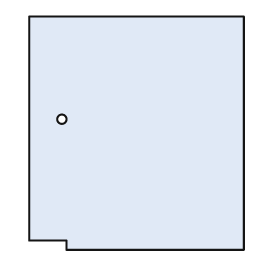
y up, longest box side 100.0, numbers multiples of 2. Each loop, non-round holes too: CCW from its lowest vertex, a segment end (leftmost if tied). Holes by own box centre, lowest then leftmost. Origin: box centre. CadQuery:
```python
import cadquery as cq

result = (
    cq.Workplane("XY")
    .moveTo(-30.0, -50.0)
    .lineTo(46.0, -50.0)
    .lineTo(46.0, 50.0)
    .lineTo(-46.0, 50.0)
    .lineTo(-46.0, -46.0)
    .lineTo(-30.0, -46.0)
    .close()
    .moveTo(-32.0, 6.0)
    .circle(2.0)
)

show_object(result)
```